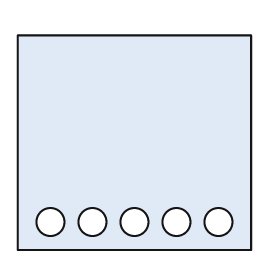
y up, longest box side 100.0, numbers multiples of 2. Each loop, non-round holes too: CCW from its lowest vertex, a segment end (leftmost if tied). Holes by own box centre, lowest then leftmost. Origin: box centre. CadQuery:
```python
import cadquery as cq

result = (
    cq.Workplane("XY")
    .moveTo(-50.0, -46.0)
    .lineTo(50.0, -46.0)
    .lineTo(50.0, 46.0)
    .lineTo(-50.0, 46.0)
    .close()
    .moveTo(-36.0, -34.0)
    .circle(6.0)
    .moveTo(-18.0, -34.0)
    .circle(6.0)
    .moveTo(0.0, -34.0)
    .circle(6.0)
    .moveTo(18.0, -34.0)
    .circle(6.0)
    .moveTo(36.0, -34.0)
    .circle(6.0)
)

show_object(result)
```